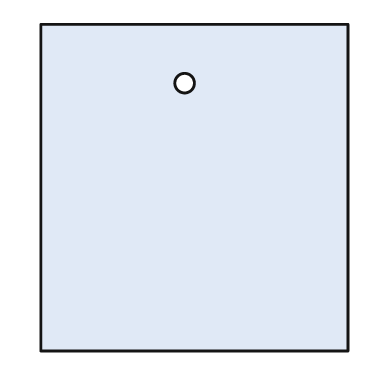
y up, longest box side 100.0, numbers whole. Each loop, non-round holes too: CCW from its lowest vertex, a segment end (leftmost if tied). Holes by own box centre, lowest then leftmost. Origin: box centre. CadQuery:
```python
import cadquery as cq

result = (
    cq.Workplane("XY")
    .moveTo(-47.0, -50.0)
    .lineTo(47.0, -50.0)
    .lineTo(47.0, 50.0)
    .lineTo(-47.0, 50.0)
    .close()
    .moveTo(-3.0, 32.0)
    .circle(3.0)
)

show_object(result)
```